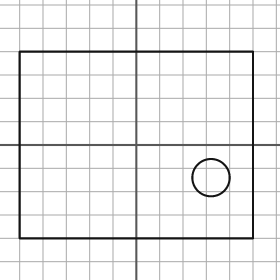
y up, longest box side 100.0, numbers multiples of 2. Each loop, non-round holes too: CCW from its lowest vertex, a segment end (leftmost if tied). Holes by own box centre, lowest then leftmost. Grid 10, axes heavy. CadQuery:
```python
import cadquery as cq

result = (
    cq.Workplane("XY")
    .moveTo(-50.0, -40.0)
    .lineTo(50.0, -40.0)
    .lineTo(50.0, 40.0)
    .lineTo(-50.0, 40.0)
    .close()
    .moveTo(32.0, -14.0)
    .circle(8.0)
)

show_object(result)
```